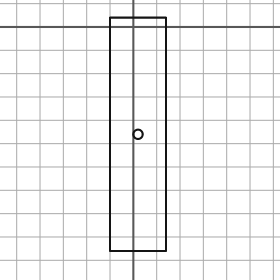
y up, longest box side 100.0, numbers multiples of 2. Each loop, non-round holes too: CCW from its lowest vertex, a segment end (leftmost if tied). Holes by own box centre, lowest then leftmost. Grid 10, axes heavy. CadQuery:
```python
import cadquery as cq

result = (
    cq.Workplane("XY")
    .moveTo(-10.0, -96.0)
    .lineTo(14.0, -96.0)
    .lineTo(14.0, 4.0)
    .lineTo(-10.0, 4.0)
    .close()
    .moveTo(2.0, -46.0)
    .circle(2.0)
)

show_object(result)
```